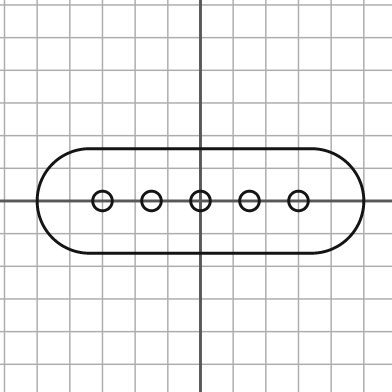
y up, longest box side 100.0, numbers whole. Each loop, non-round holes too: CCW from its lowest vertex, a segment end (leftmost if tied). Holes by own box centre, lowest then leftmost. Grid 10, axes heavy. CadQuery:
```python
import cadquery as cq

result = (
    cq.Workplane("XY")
    .moveTo(-34.0, -16.0)
    .lineTo(34.0, -16.0)
    .threePointArc((50.0, 0.0), (34.0, 16.0))
    .lineTo(-34.0, 16.0)
    .threePointArc((-50.0, 0.0), (-34.0, -16.0))
    .close()
    .moveTo(-30.0, 0.0)
    .circle(3.0)
    .moveTo(-15.0, 0.0)
    .circle(3.0)
    .moveTo(0.0, 0.0)
    .circle(3.0)
    .moveTo(15.0, 0.0)
    .circle(3.0)
    .moveTo(30.0, 0.0)
    .circle(3.0)
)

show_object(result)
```